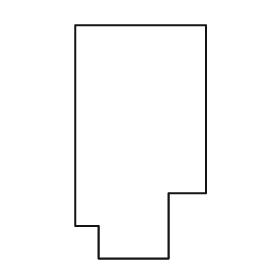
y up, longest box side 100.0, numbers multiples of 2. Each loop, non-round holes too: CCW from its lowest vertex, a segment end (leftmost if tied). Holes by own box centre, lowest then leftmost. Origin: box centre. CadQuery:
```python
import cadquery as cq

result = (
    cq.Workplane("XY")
    .moveTo(-18.0, -50.0)
    .lineTo(12.0, -50.0)
    .lineTo(12.0, -22.0)
    .lineTo(28.0, -22.0)
    .lineTo(28.0, 50.0)
    .lineTo(-28.0, 50.0)
    .lineTo(-28.0, -36.0)
    .lineTo(-18.0, -36.0)
    .close()
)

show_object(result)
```